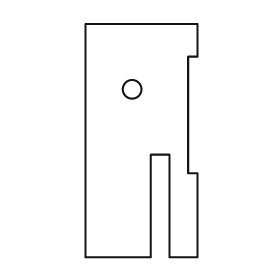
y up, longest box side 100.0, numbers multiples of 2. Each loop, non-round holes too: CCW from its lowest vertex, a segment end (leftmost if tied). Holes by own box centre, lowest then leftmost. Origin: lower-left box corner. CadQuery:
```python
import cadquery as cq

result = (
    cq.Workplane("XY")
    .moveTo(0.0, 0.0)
    .lineTo(28.0, 0.0)
    .lineTo(28.0, 44.0)
    .lineTo(36.0, 44.0)
    .lineTo(36.0, 0.0)
    .lineTo(48.0, 0.0)
    .lineTo(48.0, 36.0)
    .lineTo(44.0, 36.0)
    .lineTo(44.0, 86.0)
    .lineTo(48.0, 86.0)
    .lineTo(48.0, 100.0)
    .lineTo(0.0, 100.0)
    .close()
    .moveTo(20.0, 72.0)
    .circle(4.0)
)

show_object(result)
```